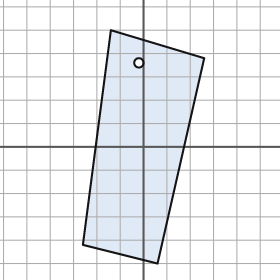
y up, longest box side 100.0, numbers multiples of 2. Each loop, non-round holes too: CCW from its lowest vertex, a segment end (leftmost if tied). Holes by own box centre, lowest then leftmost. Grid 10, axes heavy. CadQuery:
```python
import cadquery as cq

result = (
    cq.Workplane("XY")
    .moveTo(6.0, -50.0)
    .lineTo(26.0, 38.0)
    .lineTo(-14.0, 50.0)
    .lineTo(-26.0, -42.0)
    .close()
    .moveTo(-2.0, 36.0)
    .circle(2.0)
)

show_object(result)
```